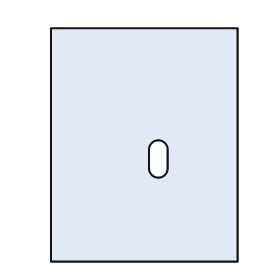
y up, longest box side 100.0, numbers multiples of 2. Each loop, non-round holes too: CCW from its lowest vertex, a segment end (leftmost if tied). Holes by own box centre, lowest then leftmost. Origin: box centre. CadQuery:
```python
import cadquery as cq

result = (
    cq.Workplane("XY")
    .moveTo(-40.0, -50.0)
    .lineTo(40.0, -50.0)
    .lineTo(40.0, 50.0)
    .lineTo(-40.0, 50.0)
    .close()
    .moveTo(2.0, -10.0)
    .threePointArc((6.0, -14.0), (10.0, -10.0))
    .lineTo(10.0, -2.0)
    .threePointArc((6.0, 2.0), (2.0, -2.0))
    .close()
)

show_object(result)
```